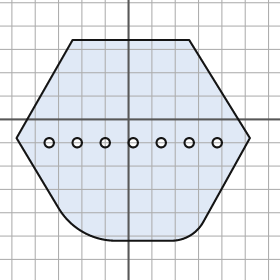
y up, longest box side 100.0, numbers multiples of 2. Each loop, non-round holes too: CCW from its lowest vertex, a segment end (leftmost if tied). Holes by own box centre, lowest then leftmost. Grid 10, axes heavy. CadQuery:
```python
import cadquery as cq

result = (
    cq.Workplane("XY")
    .moveTo(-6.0, -52.0)
    .lineTo(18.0, -52.0)
    .threePointArc((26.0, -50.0), (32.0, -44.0))
    .lineTo(52.0, -8.0)
    .lineTo(26.0, 34.0)
    .lineTo(-24.0, 34.0)
    .lineTo(-48.0, -8.0)
    .lineTo(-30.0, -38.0)
    .threePointArc((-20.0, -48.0), (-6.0, -52.0))
    .close()
    .moveTo(-34.0, -10.0)
    .circle(2.0)
    .moveTo(-22.0, -10.0)
    .circle(2.0)
    .moveTo(-10.0, -10.0)
    .circle(2.0)
    .moveTo(2.0, -10.0)
    .circle(2.0)
    .moveTo(14.0, -10.0)
    .circle(2.0)
    .moveTo(26.0, -10.0)
    .circle(2.0)
    .moveTo(38.0, -10.0)
    .circle(2.0)
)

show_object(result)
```